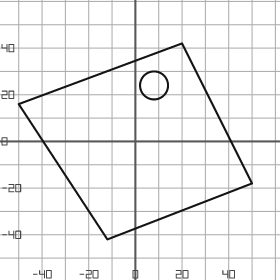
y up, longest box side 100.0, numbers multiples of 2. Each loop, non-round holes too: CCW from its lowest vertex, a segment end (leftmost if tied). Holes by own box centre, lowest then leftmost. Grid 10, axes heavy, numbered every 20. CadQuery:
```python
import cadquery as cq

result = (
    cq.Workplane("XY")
    .moveTo(-12.0, -42.0)
    .lineTo(50.0, -18.0)
    .lineTo(20.0, 42.0)
    .lineTo(-50.0, 16.0)
    .close()
    .moveTo(8.0, 24.0)
    .circle(6.0)
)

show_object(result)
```